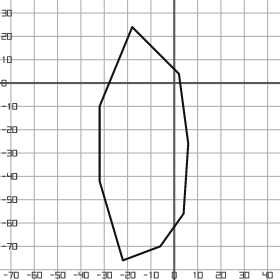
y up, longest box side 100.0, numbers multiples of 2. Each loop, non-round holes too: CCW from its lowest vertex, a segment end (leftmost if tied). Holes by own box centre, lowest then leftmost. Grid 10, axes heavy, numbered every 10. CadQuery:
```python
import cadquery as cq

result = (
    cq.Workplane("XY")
    .moveTo(-22.0, -76.0)
    .lineTo(-6.0, -70.0)
    .lineTo(4.0, -56.0)
    .lineTo(6.0, -26.0)
    .lineTo(2.0, 4.0)
    .lineTo(-18.0, 24.0)
    .lineTo(-32.0, -10.0)
    .lineTo(-32.0, -42.0)
    .close()
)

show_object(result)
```